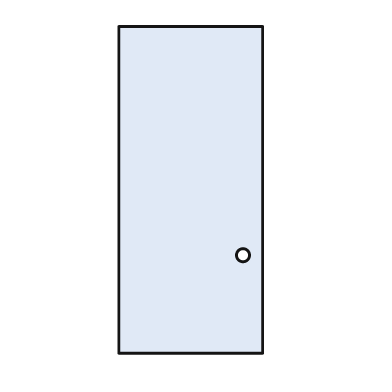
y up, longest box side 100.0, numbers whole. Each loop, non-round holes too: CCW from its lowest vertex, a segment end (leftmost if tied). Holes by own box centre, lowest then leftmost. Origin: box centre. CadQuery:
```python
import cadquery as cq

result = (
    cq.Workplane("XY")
    .moveTo(-22.0, -50.0)
    .lineTo(22.0, -50.0)
    .lineTo(22.0, 50.0)
    .lineTo(-22.0, 50.0)
    .close()
    .moveTo(16.0, -20.0)
    .circle(2.0)
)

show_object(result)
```